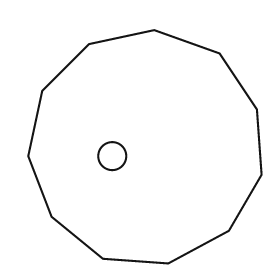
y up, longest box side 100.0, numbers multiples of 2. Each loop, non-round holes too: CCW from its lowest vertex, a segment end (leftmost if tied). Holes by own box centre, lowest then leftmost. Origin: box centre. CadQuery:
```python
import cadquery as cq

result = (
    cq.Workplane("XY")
    .moveTo(10.0, -50.0)
    .lineTo(36.0, -36.0)
    .lineTo(50.0, -12.0)
    .lineTo(48.0, 16.0)
    .lineTo(32.0, 40.0)
    .lineTo(4.0, 50.0)
    .lineTo(-24.0, 44.0)
    .lineTo(-44.0, 24.0)
    .lineTo(-50.0, -4.0)
    .lineTo(-40.0, -30.0)
    .lineTo(-18.0, -48.0)
    .close()
    .moveTo(-14.0, -4.0)
    .circle(6.0)
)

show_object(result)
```